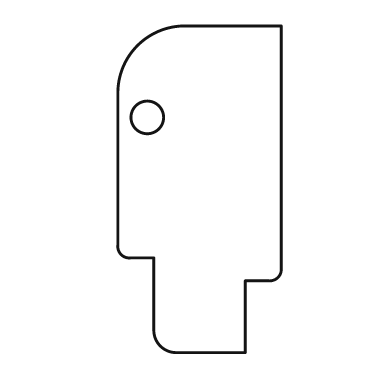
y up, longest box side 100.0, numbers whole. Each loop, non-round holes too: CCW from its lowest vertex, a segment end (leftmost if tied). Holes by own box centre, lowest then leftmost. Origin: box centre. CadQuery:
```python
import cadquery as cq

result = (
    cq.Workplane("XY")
    .moveTo(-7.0, -50.0)
    .lineTo(14.0, -50.0)
    .lineTo(14.0, -28.0)
    .lineTo(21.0, -28.0)
    .threePointArc((24.0, -27.0), (25.0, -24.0))
    .lineTo(25.0, 50.0)
    .lineTo(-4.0, 50.0)
    .threePointArc((-19.0, 44.0), (-25.0, 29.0))
    .lineTo(-25.0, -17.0)
    .threePointArc((-24.0, -20.0), (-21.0, -21.0))
    .lineTo(-14.0, -21.0)
    .lineTo(-14.0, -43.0)
    .threePointArc((-12.0, -48.0), (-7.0, -50.0))
    .close()
    .moveTo(-16.0, 22.0)
    .circle(5.0)
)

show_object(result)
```